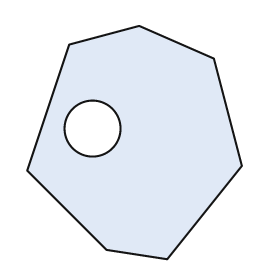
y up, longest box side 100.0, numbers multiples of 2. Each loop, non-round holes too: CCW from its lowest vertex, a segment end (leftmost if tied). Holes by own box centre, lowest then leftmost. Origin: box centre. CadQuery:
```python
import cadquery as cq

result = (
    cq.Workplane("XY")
    .moveTo(14.0, -50.0)
    .lineTo(46.0, -10.0)
    .lineTo(34.0, 36.0)
    .lineTo(2.0, 50.0)
    .lineTo(-28.0, 42.0)
    .lineTo(-46.0, -12.0)
    .lineTo(-12.0, -46.0)
    .close()
    .moveTo(-18.0, 6.0)
    .circle(12.0)
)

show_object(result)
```